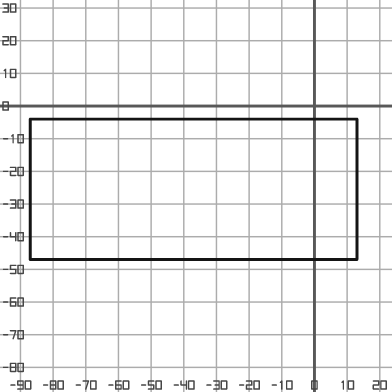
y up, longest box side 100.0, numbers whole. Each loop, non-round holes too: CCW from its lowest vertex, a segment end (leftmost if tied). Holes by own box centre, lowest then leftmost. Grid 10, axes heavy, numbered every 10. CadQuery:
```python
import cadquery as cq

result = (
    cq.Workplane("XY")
    .moveTo(-87.0, -47.0)
    .lineTo(13.0, -47.0)
    .lineTo(13.0, -4.0)
    .lineTo(-87.0, -4.0)
    .close()
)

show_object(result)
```